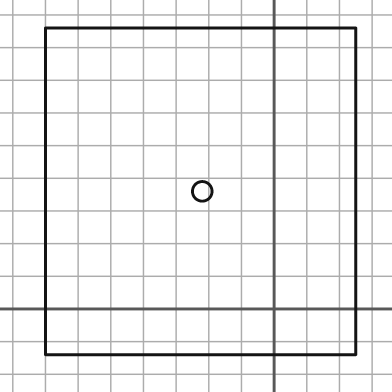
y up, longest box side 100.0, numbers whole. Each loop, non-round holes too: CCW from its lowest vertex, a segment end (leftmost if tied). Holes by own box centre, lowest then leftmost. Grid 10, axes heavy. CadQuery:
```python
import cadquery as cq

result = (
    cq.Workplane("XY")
    .moveTo(-70.0, -14.0)
    .lineTo(25.0, -14.0)
    .lineTo(25.0, 86.0)
    .lineTo(-70.0, 86.0)
    .close()
    .moveTo(-22.0, 36.0)
    .circle(3.0)
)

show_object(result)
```